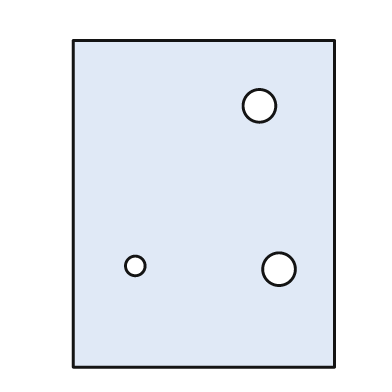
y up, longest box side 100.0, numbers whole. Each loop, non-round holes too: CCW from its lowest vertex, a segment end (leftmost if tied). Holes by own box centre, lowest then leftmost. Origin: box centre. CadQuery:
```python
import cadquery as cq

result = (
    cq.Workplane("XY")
    .moveTo(-40.0, -50.0)
    .lineTo(40.0, -50.0)
    .lineTo(40.0, 50.0)
    .lineTo(-40.0, 50.0)
    .close()
    .moveTo(23.0, -20.0)
    .circle(5.0)
    .moveTo(-21.0, -19.0)
    .circle(3.0)
    .moveTo(17.0, 30.0)
    .circle(5.0)
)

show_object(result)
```